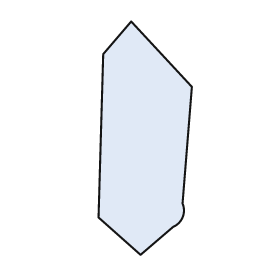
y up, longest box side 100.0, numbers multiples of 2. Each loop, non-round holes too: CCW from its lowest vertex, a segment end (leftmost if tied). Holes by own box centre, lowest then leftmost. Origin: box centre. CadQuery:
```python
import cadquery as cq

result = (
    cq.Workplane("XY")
    .moveTo(-2.0, -50.0)
    .lineTo(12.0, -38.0)
    .threePointArc((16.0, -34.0), (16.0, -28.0))
    .lineTo(20.0, 22.0)
    .lineTo(-6.0, 50.0)
    .lineTo(-18.0, 36.0)
    .lineTo(-20.0, -34.0)
    .close()
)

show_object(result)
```